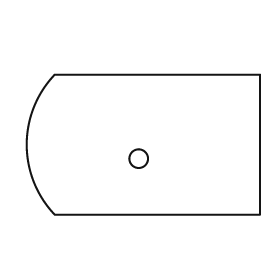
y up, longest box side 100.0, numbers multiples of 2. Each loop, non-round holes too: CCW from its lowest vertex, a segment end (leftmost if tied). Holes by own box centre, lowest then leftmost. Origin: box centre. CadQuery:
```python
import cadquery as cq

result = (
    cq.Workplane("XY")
    .moveTo(-38.0, -30.0)
    .lineTo(50.0, -30.0)
    .lineTo(50.0, 30.0)
    .lineTo(-38.0, 30.0)
    .threePointArc((-50.0, 0.0), (-38.0, -30.0))
    .close()
    .moveTo(-2.0, -6.0)
    .circle(4.0)
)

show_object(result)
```